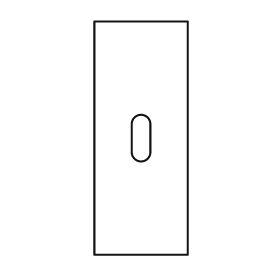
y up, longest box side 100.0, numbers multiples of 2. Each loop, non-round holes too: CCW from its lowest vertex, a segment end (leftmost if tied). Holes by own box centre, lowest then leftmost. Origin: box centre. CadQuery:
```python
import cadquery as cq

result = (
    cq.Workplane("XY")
    .moveTo(-20.0, -50.0)
    .lineTo(20.0, -50.0)
    .lineTo(20.0, 50.0)
    .lineTo(-20.0, 50.0)
    .close()
    .moveTo(-4.0, -6.0)
    .threePointArc((0.0, -10.0), (4.0, -6.0))
    .lineTo(4.0, 6.0)
    .threePointArc((0.0, 10.0), (-4.0, 6.0))
    .close()
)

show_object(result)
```